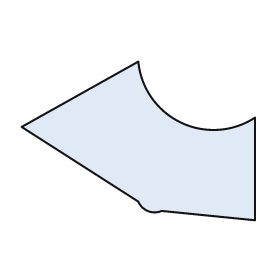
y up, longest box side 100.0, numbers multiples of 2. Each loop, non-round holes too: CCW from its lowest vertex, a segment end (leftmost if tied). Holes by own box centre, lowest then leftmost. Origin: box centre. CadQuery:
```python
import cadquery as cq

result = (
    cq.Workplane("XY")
    .moveTo(50.0, -34.0)
    .lineTo(50.0, 10.0)
    .threePointArc((18.0, 8.0), (0.0, 34.0))
    .lineTo(-50.0, 6.0)
    .lineTo(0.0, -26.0)
    .threePointArc((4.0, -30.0), (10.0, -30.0))
    .close()
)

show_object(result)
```